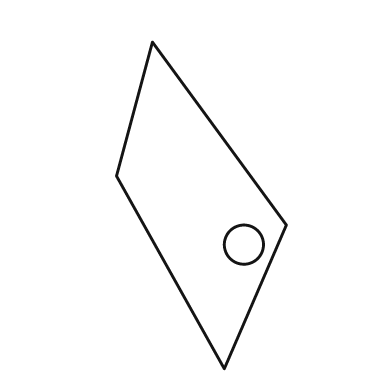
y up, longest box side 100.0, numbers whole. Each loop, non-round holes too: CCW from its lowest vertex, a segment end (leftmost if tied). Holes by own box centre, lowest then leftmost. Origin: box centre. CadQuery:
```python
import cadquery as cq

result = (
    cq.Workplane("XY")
    .moveTo(7.0, -50.0)
    .lineTo(26.0, -6.0)
    .lineTo(-15.0, 50.0)
    .lineTo(-26.0, 9.0)
    .close()
    .moveTo(13.0, -12.0)
    .circle(6.0)
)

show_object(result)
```